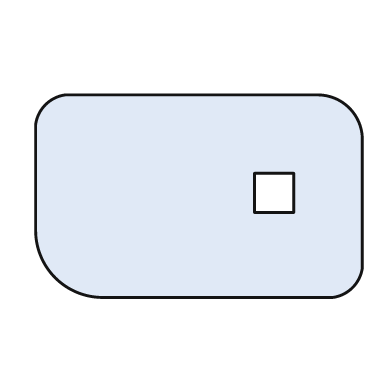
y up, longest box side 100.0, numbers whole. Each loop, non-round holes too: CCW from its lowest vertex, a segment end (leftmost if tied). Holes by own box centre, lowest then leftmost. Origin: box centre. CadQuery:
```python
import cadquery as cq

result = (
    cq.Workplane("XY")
    .moveTo(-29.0, -31.0)
    .lineTo(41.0, -31.0)
    .threePointArc((47.0, -28.0), (50.0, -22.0))
    .lineTo(50.0, 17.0)
    .threePointArc((46.0, 27.0), (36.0, 31.0))
    .lineTo(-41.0, 31.0)
    .threePointArc((-47.0, 28.0), (-50.0, 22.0))
    .lineTo(-50.0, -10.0)
    .threePointArc((-44.0, -25.0), (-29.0, -31.0))
    .close()
    .moveTo(17.0, -5.0)
    .lineTo(29.0, -5.0)
    .lineTo(29.0, 7.0)
    .lineTo(17.0, 7.0)
    .close()
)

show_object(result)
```